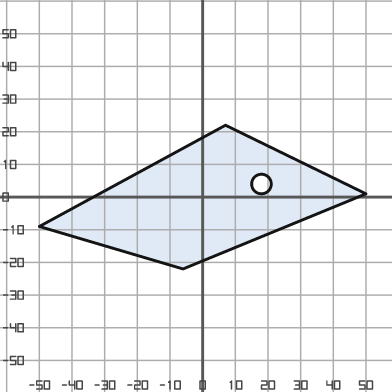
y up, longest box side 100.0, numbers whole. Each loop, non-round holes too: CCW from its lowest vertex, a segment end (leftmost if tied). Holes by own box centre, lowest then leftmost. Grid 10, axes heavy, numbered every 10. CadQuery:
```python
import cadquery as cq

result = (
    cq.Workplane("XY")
    .moveTo(-6.0, -22.0)
    .lineTo(50.0, 1.0)
    .lineTo(7.0, 22.0)
    .lineTo(-50.0, -9.0)
    .close()
    .moveTo(18.0, 4.0)
    .circle(3.0)
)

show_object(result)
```